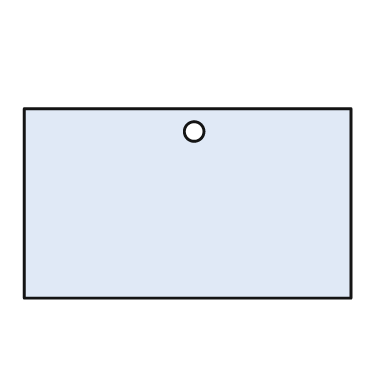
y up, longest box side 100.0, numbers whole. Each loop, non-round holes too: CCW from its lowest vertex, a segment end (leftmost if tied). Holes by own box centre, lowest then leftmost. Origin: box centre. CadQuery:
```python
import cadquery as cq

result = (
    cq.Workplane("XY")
    .moveTo(-50.0, -29.0)
    .lineTo(50.0, -29.0)
    .lineTo(50.0, 29.0)
    .lineTo(-50.0, 29.0)
    .close()
    .moveTo(2.0, 22.0)
    .circle(3.0)
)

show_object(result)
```